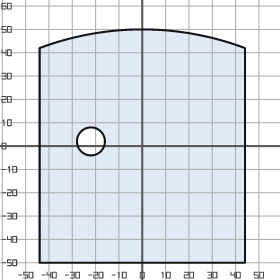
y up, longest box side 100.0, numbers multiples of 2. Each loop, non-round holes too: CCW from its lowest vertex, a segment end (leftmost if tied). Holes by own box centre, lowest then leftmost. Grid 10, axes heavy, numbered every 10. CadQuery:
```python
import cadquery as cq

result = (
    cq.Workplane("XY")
    .moveTo(-44.0, -50.0)
    .lineTo(44.0, -50.0)
    .lineTo(44.0, 42.0)
    .threePointArc((0.0, 50.0), (-44.0, 42.0))
    .close()
    .moveTo(-22.0, 2.0)
    .circle(6.0)
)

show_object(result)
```